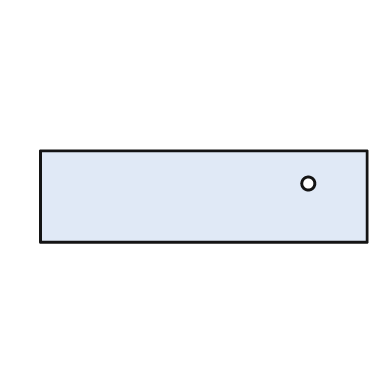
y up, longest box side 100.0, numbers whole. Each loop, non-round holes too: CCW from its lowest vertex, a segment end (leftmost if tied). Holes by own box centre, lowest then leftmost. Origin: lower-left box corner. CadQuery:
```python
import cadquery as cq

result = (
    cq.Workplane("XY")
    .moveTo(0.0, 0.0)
    .lineTo(100.0, 0.0)
    .lineTo(100.0, 28.0)
    .lineTo(0.0, 28.0)
    .close()
    .moveTo(82.0, 18.0)
    .circle(2.0)
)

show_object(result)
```